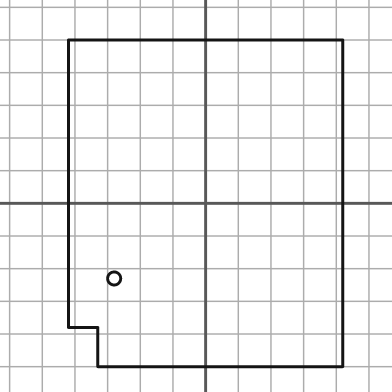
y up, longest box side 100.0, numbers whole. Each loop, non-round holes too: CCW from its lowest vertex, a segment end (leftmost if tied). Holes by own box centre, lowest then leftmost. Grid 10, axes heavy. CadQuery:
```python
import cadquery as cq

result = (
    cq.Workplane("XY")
    .moveTo(-33.0, -50.0)
    .lineTo(42.0, -50.0)
    .lineTo(42.0, 50.0)
    .lineTo(-42.0, 50.0)
    .lineTo(-42.0, -38.0)
    .lineTo(-33.0, -38.0)
    .close()
    .moveTo(-28.0, -23.0)
    .circle(2.0)
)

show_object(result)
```